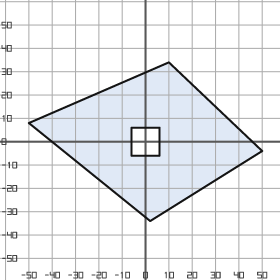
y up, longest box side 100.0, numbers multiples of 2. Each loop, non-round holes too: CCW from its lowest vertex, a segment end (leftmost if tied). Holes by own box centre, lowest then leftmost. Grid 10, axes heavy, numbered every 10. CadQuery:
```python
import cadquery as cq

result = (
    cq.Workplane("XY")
    .moveTo(2.0, -34.0)
    .lineTo(50.0, -4.0)
    .lineTo(10.0, 34.0)
    .lineTo(-50.0, 8.0)
    .close()
    .moveTo(-6.0, -6.0)
    .lineTo(6.0, -6.0)
    .lineTo(6.0, 6.0)
    .lineTo(-6.0, 6.0)
    .close()
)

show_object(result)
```